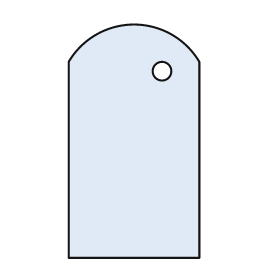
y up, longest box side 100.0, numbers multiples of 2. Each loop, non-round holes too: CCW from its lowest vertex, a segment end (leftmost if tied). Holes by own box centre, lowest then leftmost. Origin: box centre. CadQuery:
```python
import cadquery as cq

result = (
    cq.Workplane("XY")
    .moveTo(-28.0, -50.0)
    .lineTo(28.0, -50.0)
    .lineTo(28.0, 34.0)
    .threePointArc((0.0, 50.0), (-28.0, 34.0))
    .close()
    .moveTo(12.0, 30.0)
    .circle(4.0)
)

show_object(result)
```